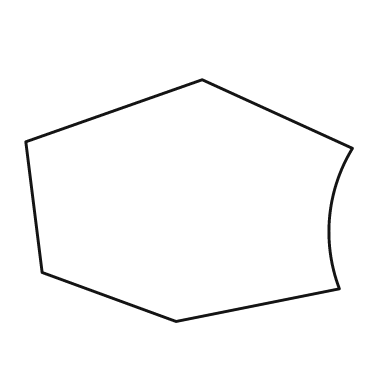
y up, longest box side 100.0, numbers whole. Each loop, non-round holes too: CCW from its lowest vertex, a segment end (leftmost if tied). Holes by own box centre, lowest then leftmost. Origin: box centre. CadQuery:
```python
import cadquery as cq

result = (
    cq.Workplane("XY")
    .moveTo(-4.0, -37.0)
    .lineTo(46.0, -27.0)
    .threePointArc((43.0, -5.0), (50.0, 16.0))
    .lineTo(4.0, 37.0)
    .lineTo(-50.0, 18.0)
    .lineTo(-45.0, -22.0)
    .close()
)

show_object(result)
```